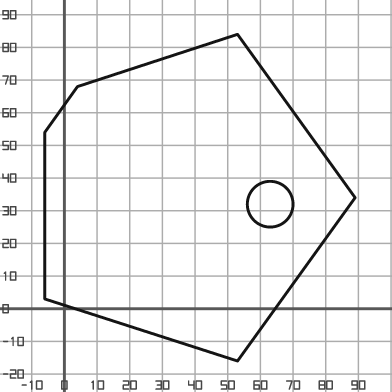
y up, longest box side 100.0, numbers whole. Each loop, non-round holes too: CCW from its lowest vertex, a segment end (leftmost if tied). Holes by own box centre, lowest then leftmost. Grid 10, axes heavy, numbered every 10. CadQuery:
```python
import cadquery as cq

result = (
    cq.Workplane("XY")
    .moveTo(53.0, -16.0)
    .lineTo(89.0, 34.0)
    .lineTo(53.0, 84.0)
    .lineTo(4.0, 68.0)
    .lineTo(-6.0, 54.0)
    .lineTo(-6.0, 3.0)
    .close()
    .moveTo(63.0, 32.0)
    .circle(7.0)
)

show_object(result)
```